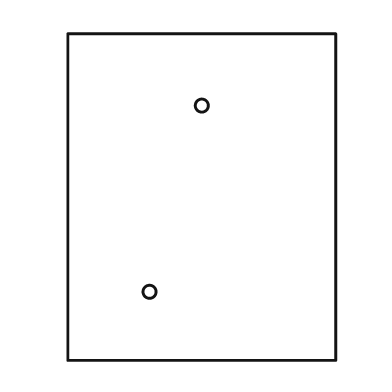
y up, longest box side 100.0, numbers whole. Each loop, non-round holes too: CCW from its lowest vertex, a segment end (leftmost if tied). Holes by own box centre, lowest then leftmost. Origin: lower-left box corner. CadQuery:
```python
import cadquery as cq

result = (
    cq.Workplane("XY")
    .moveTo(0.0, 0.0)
    .lineTo(82.0, 0.0)
    .lineTo(82.0, 100.0)
    .lineTo(0.0, 100.0)
    .close()
    .moveTo(25.0, 21.0)
    .circle(2.0)
    .moveTo(41.0, 78.0)
    .circle(2.0)
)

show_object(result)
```